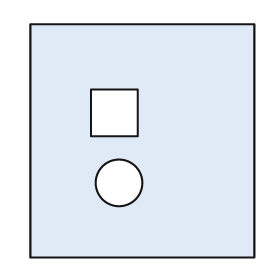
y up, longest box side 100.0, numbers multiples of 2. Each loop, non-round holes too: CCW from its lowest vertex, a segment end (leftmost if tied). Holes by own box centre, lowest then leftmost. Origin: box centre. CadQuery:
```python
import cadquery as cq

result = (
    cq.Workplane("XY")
    .moveTo(-48.0, -50.0)
    .lineTo(48.0, -50.0)
    .lineTo(48.0, 50.0)
    .lineTo(-48.0, 50.0)
    .close()
    .moveTo(-10.0, -18.0)
    .circle(10.0)
    .moveTo(-22.0, 2.0)
    .lineTo(-2.0, 2.0)
    .lineTo(-2.0, 22.0)
    .lineTo(-22.0, 22.0)
    .close()
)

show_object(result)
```